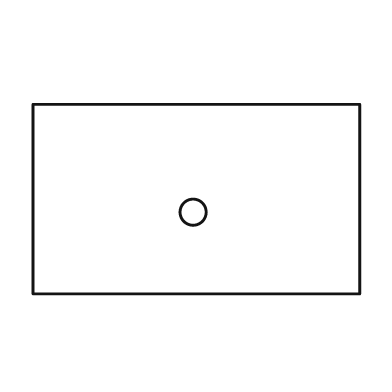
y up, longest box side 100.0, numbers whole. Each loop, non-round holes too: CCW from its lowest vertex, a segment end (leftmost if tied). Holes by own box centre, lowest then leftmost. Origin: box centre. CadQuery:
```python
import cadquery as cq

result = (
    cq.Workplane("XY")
    .moveTo(-50.0, -29.0)
    .lineTo(50.0, -29.0)
    .lineTo(50.0, 29.0)
    .lineTo(-50.0, 29.0)
    .close()
    .moveTo(-1.0, -4.0)
    .circle(4.0)
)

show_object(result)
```